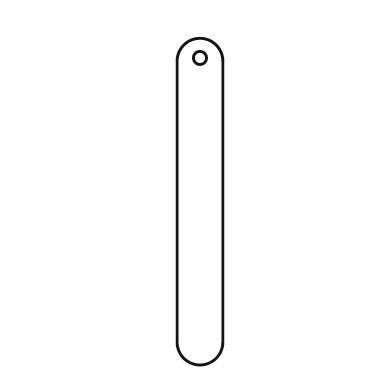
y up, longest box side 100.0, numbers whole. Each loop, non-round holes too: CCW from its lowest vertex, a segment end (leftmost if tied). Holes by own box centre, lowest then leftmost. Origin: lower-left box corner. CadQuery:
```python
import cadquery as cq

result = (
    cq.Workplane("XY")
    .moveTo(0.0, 7.0)
    .threePointArc((7.0, 0.0), (14.0, 7.0))
    .lineTo(14.0, 93.0)
    .threePointArc((7.0, 100.0), (0.0, 93.0))
    .close()
    .moveTo(7.0, 94.0)
    .circle(2.0)
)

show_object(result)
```